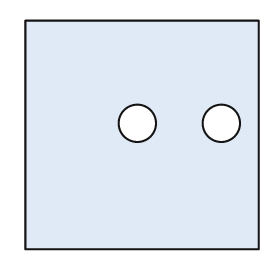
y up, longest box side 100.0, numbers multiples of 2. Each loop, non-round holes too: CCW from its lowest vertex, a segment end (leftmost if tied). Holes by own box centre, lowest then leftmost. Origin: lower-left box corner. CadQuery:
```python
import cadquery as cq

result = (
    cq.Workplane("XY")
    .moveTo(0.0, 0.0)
    .lineTo(100.0, 0.0)
    .lineTo(100.0, 98.0)
    .lineTo(0.0, 98.0)
    .close()
    .moveTo(48.0, 54.0)
    .circle(8.0)
    .moveTo(84.0, 54.0)
    .circle(8.0)
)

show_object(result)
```